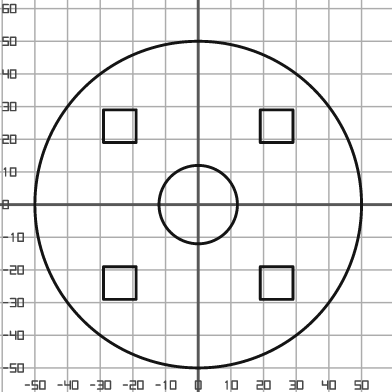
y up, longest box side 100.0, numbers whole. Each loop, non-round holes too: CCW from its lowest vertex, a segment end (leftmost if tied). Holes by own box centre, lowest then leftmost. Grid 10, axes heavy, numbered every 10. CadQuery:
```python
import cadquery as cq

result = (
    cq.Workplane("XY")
    .moveTo(0.0, 0.0)
    .circle(50.0)
    .moveTo(-29.0, -29.0)
    .lineTo(-19.0, -29.0)
    .lineTo(-19.0, -19.0)
    .lineTo(-29.0, -19.0)
    .close()
    .moveTo(19.0, -29.0)
    .lineTo(29.0, -29.0)
    .lineTo(29.0, -19.0)
    .lineTo(19.0, -19.0)
    .close()
    .moveTo(0.0, 0.0)
    .circle(12.0)
    .moveTo(-29.0, 19.0)
    .lineTo(-19.0, 19.0)
    .lineTo(-19.0, 29.0)
    .lineTo(-29.0, 29.0)
    .close()
    .moveTo(19.0, 19.0)
    .lineTo(29.0, 19.0)
    .lineTo(29.0, 29.0)
    .lineTo(19.0, 29.0)
    .close()
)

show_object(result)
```